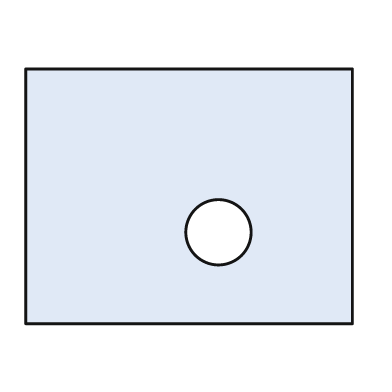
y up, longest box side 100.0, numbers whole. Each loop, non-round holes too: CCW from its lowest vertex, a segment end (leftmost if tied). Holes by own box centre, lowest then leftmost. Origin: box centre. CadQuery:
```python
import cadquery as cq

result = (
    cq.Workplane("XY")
    .moveTo(-50.0, -39.0)
    .lineTo(50.0, -39.0)
    .lineTo(50.0, 39.0)
    .lineTo(-50.0, 39.0)
    .close()
    .moveTo(9.0, -11.0)
    .circle(10.0)
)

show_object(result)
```